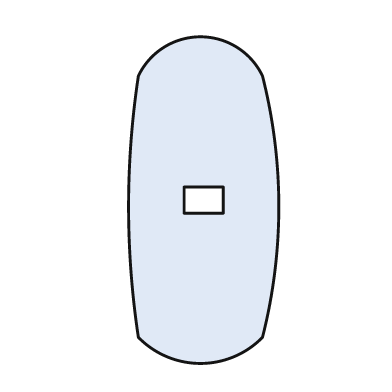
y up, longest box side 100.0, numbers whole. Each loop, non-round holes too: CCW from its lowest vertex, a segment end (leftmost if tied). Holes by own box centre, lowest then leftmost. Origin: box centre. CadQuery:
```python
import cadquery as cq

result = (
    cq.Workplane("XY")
    .moveTo(-20.0, -42.0)
    .threePointArc((-1.0, -50.0), (18.0, -42.0))
    .threePointArc((23.0, -2.0), (18.0, 38.0))
    .threePointArc((-1.0, 50.0), (-20.0, 38.0))
    .threePointArc((-23.0, -2.0), (-20.0, -42.0))
    .close()
    .moveTo(-6.0, -4.0)
    .lineTo(6.0, -4.0)
    .lineTo(6.0, 4.0)
    .lineTo(-6.0, 4.0)
    .close()
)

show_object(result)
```